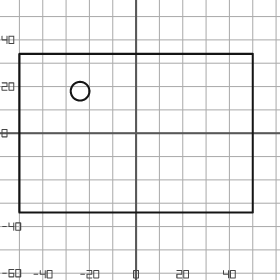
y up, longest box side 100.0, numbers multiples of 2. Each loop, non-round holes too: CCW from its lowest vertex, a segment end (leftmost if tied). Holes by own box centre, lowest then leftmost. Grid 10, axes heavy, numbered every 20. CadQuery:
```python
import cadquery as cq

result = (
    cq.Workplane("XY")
    .moveTo(-50.0, -34.0)
    .lineTo(50.0, -34.0)
    .lineTo(50.0, 34.0)
    .lineTo(-50.0, 34.0)
    .close()
    .moveTo(-24.0, 18.0)
    .circle(4.0)
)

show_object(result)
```